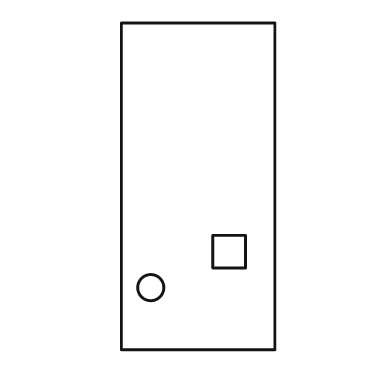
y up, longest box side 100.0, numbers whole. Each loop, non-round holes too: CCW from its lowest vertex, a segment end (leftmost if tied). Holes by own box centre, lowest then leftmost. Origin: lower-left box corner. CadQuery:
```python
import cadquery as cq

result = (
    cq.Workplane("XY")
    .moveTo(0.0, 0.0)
    .lineTo(47.0, 0.0)
    .lineTo(47.0, 100.0)
    .lineTo(0.0, 100.0)
    .close()
    .moveTo(9.0, 19.0)
    .circle(4.0)
    .moveTo(28.0, 25.0)
    .lineTo(38.0, 25.0)
    .lineTo(38.0, 35.0)
    .lineTo(28.0, 35.0)
    .close()
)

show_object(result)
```